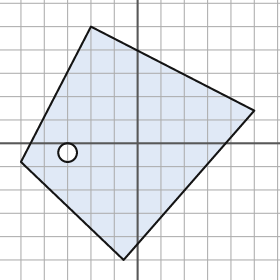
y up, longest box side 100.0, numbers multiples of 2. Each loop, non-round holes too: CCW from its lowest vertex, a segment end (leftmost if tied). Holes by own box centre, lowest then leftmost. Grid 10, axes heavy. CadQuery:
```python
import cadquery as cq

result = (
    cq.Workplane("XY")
    .moveTo(-6.0, -50.0)
    .lineTo(50.0, 14.0)
    .lineTo(-20.0, 50.0)
    .lineTo(-50.0, -8.0)
    .close()
    .moveTo(-30.0, -4.0)
    .circle(4.0)
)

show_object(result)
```